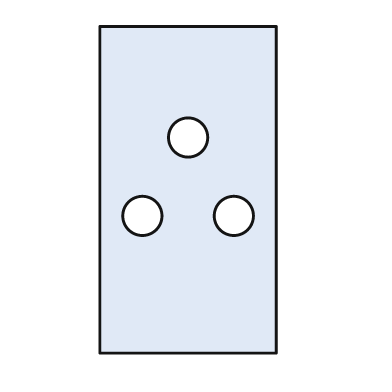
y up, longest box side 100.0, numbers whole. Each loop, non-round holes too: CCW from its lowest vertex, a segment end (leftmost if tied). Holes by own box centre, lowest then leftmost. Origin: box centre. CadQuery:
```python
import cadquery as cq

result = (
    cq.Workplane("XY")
    .moveTo(-27.0, -50.0)
    .lineTo(27.0, -50.0)
    .lineTo(27.0, 50.0)
    .lineTo(-27.0, 50.0)
    .close()
    .moveTo(-14.0, -8.0)
    .circle(6.0)
    .moveTo(14.0, -8.0)
    .circle(6.0)
    .moveTo(0.0, 16.0)
    .circle(6.0)
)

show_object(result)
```